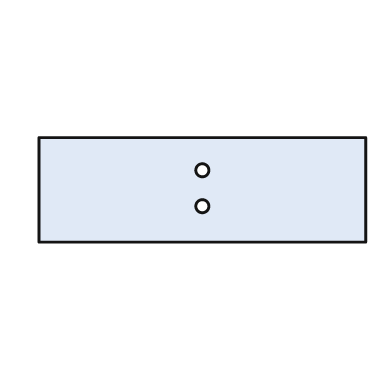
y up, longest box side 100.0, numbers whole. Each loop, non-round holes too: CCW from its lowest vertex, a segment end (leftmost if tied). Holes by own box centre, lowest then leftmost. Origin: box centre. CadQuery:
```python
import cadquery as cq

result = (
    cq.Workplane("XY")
    .moveTo(-50.0, -16.0)
    .lineTo(50.0, -16.0)
    .lineTo(50.0, 16.0)
    .lineTo(-50.0, 16.0)
    .close()
    .moveTo(0.0, -5.0)
    .circle(2.0)
    .moveTo(0.0, 6.0)
    .circle(2.0)
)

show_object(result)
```